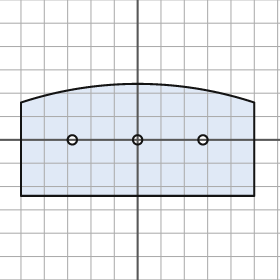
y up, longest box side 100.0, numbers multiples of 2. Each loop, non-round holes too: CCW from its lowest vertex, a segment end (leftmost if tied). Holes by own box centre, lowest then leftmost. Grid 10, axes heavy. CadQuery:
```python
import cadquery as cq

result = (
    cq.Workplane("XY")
    .moveTo(-50.0, -24.0)
    .lineTo(50.0, -24.0)
    .lineTo(50.0, 16.0)
    .threePointArc((0.0, 24.0), (-50.0, 16.0))
    .close()
    .moveTo(-28.0, 0.0)
    .circle(2.0)
    .moveTo(0.0, 0.0)
    .circle(2.0)
    .moveTo(28.0, 0.0)
    .circle(2.0)
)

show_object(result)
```